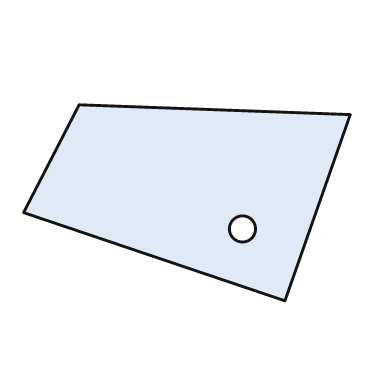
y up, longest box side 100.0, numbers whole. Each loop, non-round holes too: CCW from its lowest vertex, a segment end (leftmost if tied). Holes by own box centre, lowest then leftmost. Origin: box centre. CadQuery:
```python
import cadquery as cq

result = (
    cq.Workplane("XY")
    .moveTo(30.0, -30.0)
    .lineTo(50.0, 27.0)
    .lineTo(-33.0, 30.0)
    .lineTo(-50.0, -3.0)
    .close()
    .moveTo(17.0, -8.0)
    .circle(4.0)
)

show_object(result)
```